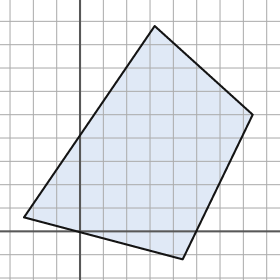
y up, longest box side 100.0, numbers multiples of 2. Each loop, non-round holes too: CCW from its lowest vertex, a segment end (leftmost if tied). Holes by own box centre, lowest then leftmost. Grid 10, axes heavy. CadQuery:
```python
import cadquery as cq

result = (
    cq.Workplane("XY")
    .moveTo(44.0, -12.0)
    .lineTo(74.0, 50.0)
    .lineTo(32.0, 88.0)
    .lineTo(-24.0, 6.0)
    .close()
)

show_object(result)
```